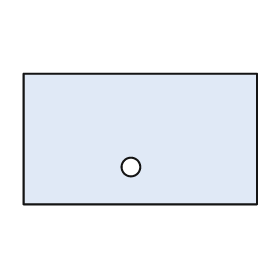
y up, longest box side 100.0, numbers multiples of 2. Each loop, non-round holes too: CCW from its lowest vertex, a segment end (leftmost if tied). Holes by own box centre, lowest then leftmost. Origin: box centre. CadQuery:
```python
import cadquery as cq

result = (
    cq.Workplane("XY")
    .moveTo(-50.0, -28.0)
    .lineTo(50.0, -28.0)
    .lineTo(50.0, 28.0)
    .lineTo(-50.0, 28.0)
    .close()
    .moveTo(-4.0, -12.0)
    .circle(4.0)
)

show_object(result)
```